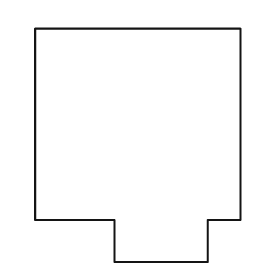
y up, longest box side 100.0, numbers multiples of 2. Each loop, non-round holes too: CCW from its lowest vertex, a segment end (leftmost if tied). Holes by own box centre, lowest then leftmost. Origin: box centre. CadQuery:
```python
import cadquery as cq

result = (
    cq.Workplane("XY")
    .moveTo(-10.0, -50.0)
    .lineTo(30.0, -50.0)
    .lineTo(30.0, -32.0)
    .lineTo(44.0, -32.0)
    .lineTo(44.0, 50.0)
    .lineTo(-44.0, 50.0)
    .lineTo(-44.0, -32.0)
    .lineTo(-10.0, -32.0)
    .close()
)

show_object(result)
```